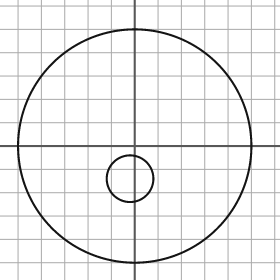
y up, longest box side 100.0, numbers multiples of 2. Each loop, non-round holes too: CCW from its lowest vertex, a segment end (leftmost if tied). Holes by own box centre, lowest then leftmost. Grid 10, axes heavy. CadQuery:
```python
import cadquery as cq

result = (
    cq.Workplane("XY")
    .moveTo(0.0, 0.0)
    .circle(50.0)
    .moveTo(-2.0, -14.0)
    .circle(10.0)
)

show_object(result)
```